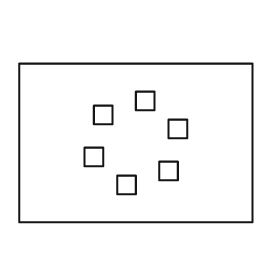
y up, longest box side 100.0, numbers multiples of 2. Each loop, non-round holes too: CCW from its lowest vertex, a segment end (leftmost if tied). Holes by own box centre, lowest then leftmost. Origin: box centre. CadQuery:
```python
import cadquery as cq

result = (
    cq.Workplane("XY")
    .moveTo(-50.0, -34.0)
    .lineTo(50.0, -34.0)
    .lineTo(50.0, 34.0)
    .lineTo(-50.0, 34.0)
    .close()
    .moveTo(-8.0, -22.0)
    .lineTo(0.0, -22.0)
    .lineTo(0.0, -14.0)
    .lineTo(-8.0, -14.0)
    .close()
    .moveTo(10.0, -16.0)
    .lineTo(18.0, -16.0)
    .lineTo(18.0, -8.0)
    .lineTo(10.0, -8.0)
    .close()
    .moveTo(-22.0, -10.0)
    .lineTo(-14.0, -10.0)
    .lineTo(-14.0, -2.0)
    .lineTo(-22.0, -2.0)
    .close()
    .moveTo(14.0, 2.0)
    .lineTo(22.0, 2.0)
    .lineTo(22.0, 10.0)
    .lineTo(14.0, 10.0)
    .close()
    .moveTo(-18.0, 8.0)
    .lineTo(-10.0, 8.0)
    .lineTo(-10.0, 16.0)
    .lineTo(-18.0, 16.0)
    .close()
    .moveTo(0.0, 14.0)
    .lineTo(8.0, 14.0)
    .lineTo(8.0, 22.0)
    .lineTo(0.0, 22.0)
    .close()
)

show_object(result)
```